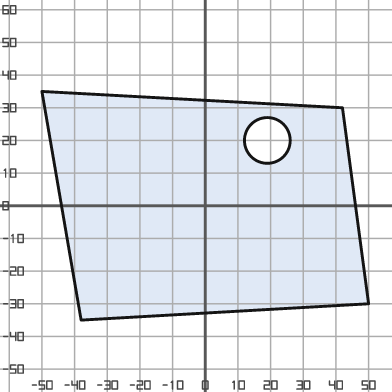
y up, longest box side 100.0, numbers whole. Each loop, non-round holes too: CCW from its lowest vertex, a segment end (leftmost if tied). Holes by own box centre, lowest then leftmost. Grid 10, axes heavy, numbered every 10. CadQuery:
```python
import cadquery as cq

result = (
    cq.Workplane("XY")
    .moveTo(-38.0, -35.0)
    .lineTo(50.0, -30.0)
    .lineTo(42.0, 30.0)
    .lineTo(-50.0, 35.0)
    .close()
    .moveTo(19.0, 20.0)
    .circle(7.0)
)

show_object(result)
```